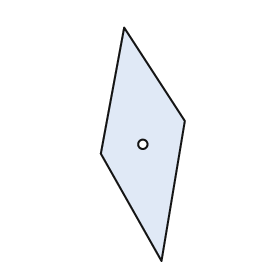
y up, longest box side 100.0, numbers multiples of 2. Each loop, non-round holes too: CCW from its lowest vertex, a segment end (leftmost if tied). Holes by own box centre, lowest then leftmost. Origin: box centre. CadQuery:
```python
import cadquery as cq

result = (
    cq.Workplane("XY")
    .moveTo(8.0, -50.0)
    .lineTo(18.0, 10.0)
    .lineTo(-8.0, 50.0)
    .lineTo(-18.0, -4.0)
    .close()
    .moveTo(0.0, 0.0)
    .circle(2.0)
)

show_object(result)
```